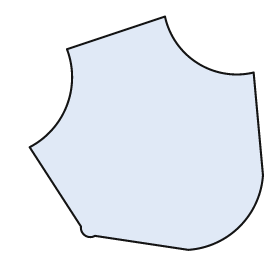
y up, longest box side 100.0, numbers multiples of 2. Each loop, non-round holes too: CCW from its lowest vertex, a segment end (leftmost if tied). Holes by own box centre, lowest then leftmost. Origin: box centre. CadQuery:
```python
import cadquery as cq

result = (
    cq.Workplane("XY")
    .moveTo(18.0, -50.0)
    .threePointArc((40.0, -40.0), (50.0, -18.0))
    .lineTo(46.0, 26.0)
    .threePointArc((22.0, 30.0), (8.0, 50.0))
    .lineTo(-34.0, 36.0)
    .threePointArc((-34.0, 12.0), (-50.0, -6.0))
    .lineTo(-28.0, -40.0)
    .threePointArc((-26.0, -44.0), (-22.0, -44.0))
    .close()
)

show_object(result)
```